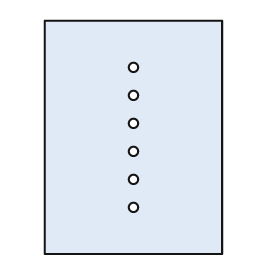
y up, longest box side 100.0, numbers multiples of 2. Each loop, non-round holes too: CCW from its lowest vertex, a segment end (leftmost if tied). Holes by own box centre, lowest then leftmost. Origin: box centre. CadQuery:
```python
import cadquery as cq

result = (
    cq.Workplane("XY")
    .moveTo(-38.0, -50.0)
    .lineTo(38.0, -50.0)
    .lineTo(38.0, 50.0)
    .lineTo(-38.0, 50.0)
    .close()
    .moveTo(0.0, -30.0)
    .circle(2.0)
    .moveTo(0.0, -18.0)
    .circle(2.0)
    .moveTo(0.0, -6.0)
    .circle(2.0)
    .moveTo(0.0, 6.0)
    .circle(2.0)
    .moveTo(0.0, 18.0)
    .circle(2.0)
    .moveTo(0.0, 30.0)
    .circle(2.0)
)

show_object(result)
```